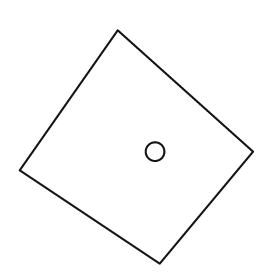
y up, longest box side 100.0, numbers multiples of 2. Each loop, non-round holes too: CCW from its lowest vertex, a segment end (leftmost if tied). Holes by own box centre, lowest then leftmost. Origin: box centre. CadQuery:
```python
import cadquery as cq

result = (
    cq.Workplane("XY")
    .moveTo(10.0, -50.0)
    .lineTo(50.0, -2.0)
    .lineTo(-8.0, 50.0)
    .lineTo(-50.0, -10.0)
    .close()
    .moveTo(8.0, -2.0)
    .circle(4.0)
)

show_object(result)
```